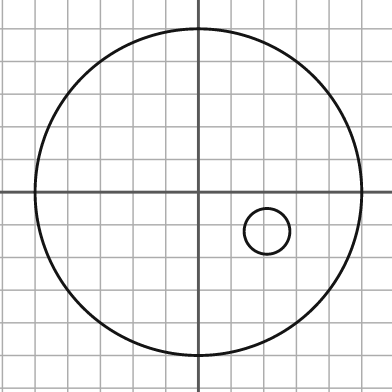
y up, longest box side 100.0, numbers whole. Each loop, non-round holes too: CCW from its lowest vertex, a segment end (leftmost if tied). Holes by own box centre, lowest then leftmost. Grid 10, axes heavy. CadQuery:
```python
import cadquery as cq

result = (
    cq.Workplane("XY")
    .moveTo(0.0, 0.0)
    .circle(50.0)
    .moveTo(21.0, -12.0)
    .circle(7.0)
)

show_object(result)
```